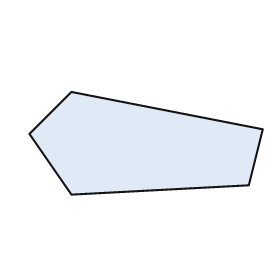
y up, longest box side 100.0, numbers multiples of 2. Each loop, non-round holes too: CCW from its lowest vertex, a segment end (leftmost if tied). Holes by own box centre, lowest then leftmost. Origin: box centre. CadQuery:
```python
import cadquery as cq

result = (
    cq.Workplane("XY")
    .moveTo(-32.0, -22.0)
    .lineTo(44.0, -18.0)
    .lineTo(50.0, 6.0)
    .lineTo(-32.0, 22.0)
    .lineTo(-50.0, 4.0)
    .close()
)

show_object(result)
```